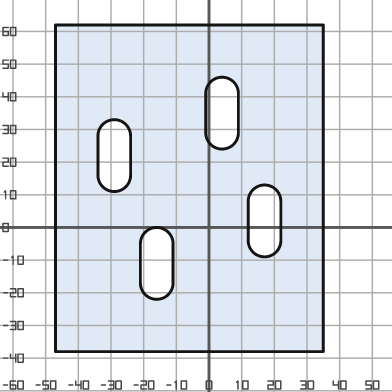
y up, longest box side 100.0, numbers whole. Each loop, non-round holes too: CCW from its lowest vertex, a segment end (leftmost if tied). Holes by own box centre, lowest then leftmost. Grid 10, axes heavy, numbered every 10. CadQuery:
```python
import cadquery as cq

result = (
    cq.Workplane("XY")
    .moveTo(-47.0, -38.0)
    .lineTo(35.0, -38.0)
    .lineTo(35.0, 62.0)
    .lineTo(-47.0, 62.0)
    .close()
    .moveTo(-21.0, -17.0)
    .threePointArc((-16.0, -22.0), (-11.0, -17.0))
    .lineTo(-11.0, -5.0)
    .threePointArc((-16.0, 0.0), (-21.0, -5.0))
    .close()
    .moveTo(12.0, -4.0)
    .threePointArc((17.0, -9.0), (22.0, -4.0))
    .lineTo(22.0, 8.0)
    .threePointArc((17.0, 13.0), (12.0, 8.0))
    .close()
    .moveTo(-34.0, 16.0)
    .threePointArc((-29.0, 11.0), (-24.0, 16.0))
    .lineTo(-24.0, 28.0)
    .threePointArc((-29.0, 33.0), (-34.0, 28.0))
    .close()
    .moveTo(-1.0, 29.0)
    .threePointArc((4.0, 24.0), (9.0, 29.0))
    .lineTo(9.0, 41.0)
    .threePointArc((4.0, 46.0), (-1.0, 41.0))
    .close()
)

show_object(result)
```